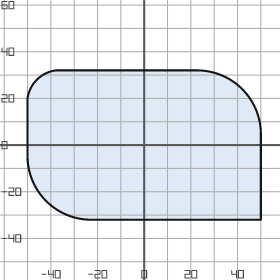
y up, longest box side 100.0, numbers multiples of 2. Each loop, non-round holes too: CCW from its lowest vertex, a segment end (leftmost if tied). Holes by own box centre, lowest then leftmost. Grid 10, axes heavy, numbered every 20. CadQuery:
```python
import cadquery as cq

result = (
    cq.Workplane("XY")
    .moveTo(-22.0, -32.0)
    .lineTo(50.0, -32.0)
    .lineTo(50.0, 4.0)
    .threePointArc((42.0, 24.0), (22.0, 32.0))
    .lineTo(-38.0, 32.0)
    .threePointArc((-46.0, 28.0), (-50.0, 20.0))
    .lineTo(-50.0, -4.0)
    .threePointArc((-42.0, -24.0), (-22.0, -32.0))
    .close()
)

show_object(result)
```